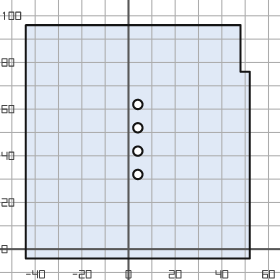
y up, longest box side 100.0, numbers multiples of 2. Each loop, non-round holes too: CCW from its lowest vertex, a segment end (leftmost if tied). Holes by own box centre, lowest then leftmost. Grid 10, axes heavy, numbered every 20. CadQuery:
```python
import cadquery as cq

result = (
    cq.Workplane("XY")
    .moveTo(-44.0, -4.0)
    .lineTo(52.0, -4.0)
    .lineTo(52.0, 76.0)
    .lineTo(48.0, 76.0)
    .lineTo(48.0, 96.0)
    .lineTo(-44.0, 96.0)
    .close()
    .moveTo(4.0, 32.0)
    .circle(2.0)
    .moveTo(4.0, 42.0)
    .circle(2.0)
    .moveTo(4.0, 52.0)
    .circle(2.0)
    .moveTo(4.0, 62.0)
    .circle(2.0)
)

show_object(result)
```